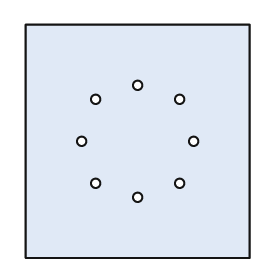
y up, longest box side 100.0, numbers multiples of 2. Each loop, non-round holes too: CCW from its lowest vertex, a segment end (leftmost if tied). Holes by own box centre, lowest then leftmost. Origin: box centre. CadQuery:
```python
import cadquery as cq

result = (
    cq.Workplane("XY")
    .moveTo(-48.0, -50.0)
    .lineTo(48.0, -50.0)
    .lineTo(48.0, 50.0)
    .lineTo(-48.0, 50.0)
    .close()
    .moveTo(0.0, -24.0)
    .circle(2.0)
    .moveTo(-18.0, -18.0)
    .circle(2.0)
    .moveTo(18.0, -18.0)
    .circle(2.0)
    .moveTo(-24.0, 0.0)
    .circle(2.0)
    .moveTo(24.0, 0.0)
    .circle(2.0)
    .moveTo(-18.0, 18.0)
    .circle(2.0)
    .moveTo(18.0, 18.0)
    .circle(2.0)
    .moveTo(0.0, 24.0)
    .circle(2.0)
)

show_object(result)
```